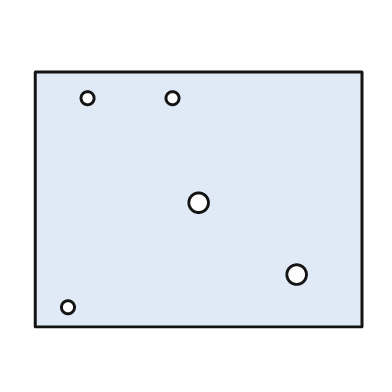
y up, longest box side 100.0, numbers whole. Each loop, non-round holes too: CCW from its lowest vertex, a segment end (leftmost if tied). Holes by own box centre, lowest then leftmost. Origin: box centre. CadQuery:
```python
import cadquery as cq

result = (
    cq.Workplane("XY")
    .moveTo(-50.0, -39.0)
    .lineTo(50.0, -39.0)
    .lineTo(50.0, 39.0)
    .lineTo(-50.0, 39.0)
    .close()
    .moveTo(-40.0, -33.0)
    .circle(2.0)
    .moveTo(30.0, -23.0)
    .circle(3.0)
    .moveTo(0.0, -1.0)
    .circle(3.0)
    .moveTo(-34.0, 31.0)
    .circle(2.0)
    .moveTo(-8.0, 31.0)
    .circle(2.0)
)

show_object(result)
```